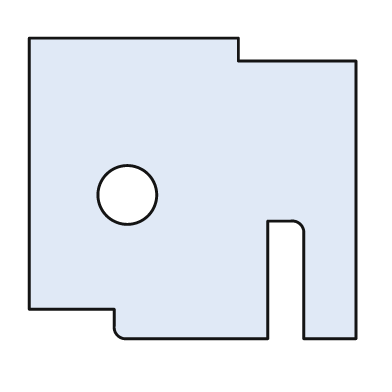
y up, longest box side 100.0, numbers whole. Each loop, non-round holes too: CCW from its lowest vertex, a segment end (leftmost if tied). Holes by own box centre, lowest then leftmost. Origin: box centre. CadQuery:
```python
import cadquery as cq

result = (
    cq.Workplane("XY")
    .moveTo(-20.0, -46.0)
    .lineTo(23.0, -46.0)
    .lineTo(23.0, -10.0)
    .lineTo(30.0, -10.0)
    .threePointArc((33.0, -11.0), (34.0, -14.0))
    .lineTo(34.0, -46.0)
    .lineTo(50.0, -46.0)
    .lineTo(50.0, 39.0)
    .lineTo(14.0, 39.0)
    .lineTo(14.0, 46.0)
    .lineTo(-50.0, 46.0)
    .lineTo(-50.0, -37.0)
    .lineTo(-24.0, -37.0)
    .lineTo(-24.0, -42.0)
    .threePointArc((-23.0, -45.0), (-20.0, -46.0))
    .close()
    .moveTo(-20.0, -2.0)
    .circle(9.0)
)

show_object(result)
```